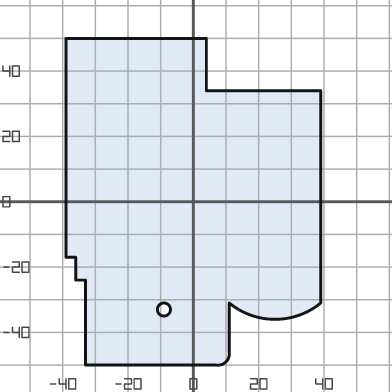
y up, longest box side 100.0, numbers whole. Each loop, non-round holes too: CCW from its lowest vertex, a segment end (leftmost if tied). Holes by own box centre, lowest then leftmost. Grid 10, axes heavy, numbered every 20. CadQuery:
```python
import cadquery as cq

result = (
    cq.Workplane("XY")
    .moveTo(-33.0, -50.0)
    .lineTo(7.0, -50.0)
    .threePointArc((10.0, -49.0), (11.0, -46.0))
    .lineTo(11.0, -31.0)
    .threePointArc((25.0, -36.0), (39.0, -31.0))
    .lineTo(39.0, 34.0)
    .lineTo(4.0, 34.0)
    .lineTo(4.0, 50.0)
    .lineTo(-39.0, 50.0)
    .lineTo(-39.0, -17.0)
    .lineTo(-36.0, -17.0)
    .lineTo(-36.0, -24.0)
    .lineTo(-33.0, -24.0)
    .close()
    .moveTo(-9.0, -33.0)
    .circle(2.0)
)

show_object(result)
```